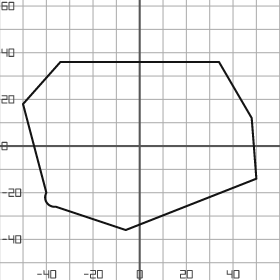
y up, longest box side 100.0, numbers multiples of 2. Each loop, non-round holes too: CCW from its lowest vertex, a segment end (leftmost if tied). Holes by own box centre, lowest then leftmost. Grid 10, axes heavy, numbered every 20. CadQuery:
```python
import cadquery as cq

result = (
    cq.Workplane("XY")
    .moveTo(-6.0, -36.0)
    .lineTo(50.0, -14.0)
    .lineTo(48.0, 12.0)
    .lineTo(34.0, 36.0)
    .lineTo(-34.0, 36.0)
    .lineTo(-50.0, 18.0)
    .lineTo(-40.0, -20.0)
    .threePointArc((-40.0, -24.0), (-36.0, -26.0))
    .close()
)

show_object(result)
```